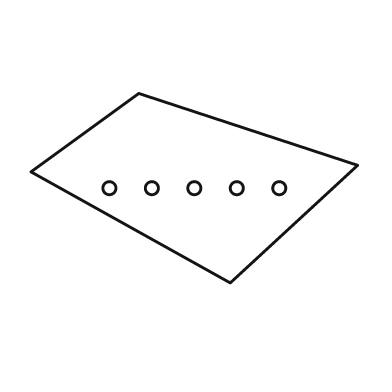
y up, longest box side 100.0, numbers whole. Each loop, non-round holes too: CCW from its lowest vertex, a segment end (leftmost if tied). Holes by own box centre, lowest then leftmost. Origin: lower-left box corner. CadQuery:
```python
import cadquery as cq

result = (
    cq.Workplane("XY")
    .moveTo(61.0, 0.0)
    .lineTo(100.0, 36.0)
    .lineTo(33.0, 58.0)
    .lineTo(0.0, 34.0)
    .close()
    .moveTo(24.0, 29.0)
    .circle(2.0)
    .moveTo(37.0, 29.0)
    .circle(2.0)
    .moveTo(50.0, 29.0)
    .circle(2.0)
    .moveTo(63.0, 29.0)
    .circle(2.0)
    .moveTo(76.0, 29.0)
    .circle(2.0)
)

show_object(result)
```